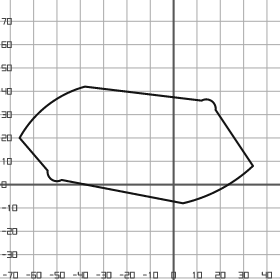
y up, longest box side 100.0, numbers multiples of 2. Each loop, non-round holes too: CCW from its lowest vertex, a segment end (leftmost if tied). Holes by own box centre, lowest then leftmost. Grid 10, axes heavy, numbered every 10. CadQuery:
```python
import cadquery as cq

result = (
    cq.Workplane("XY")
    .moveTo(4.0, -8.0)
    .threePointArc((20.0, -2.0), (34.0, 8.0))
    .lineTo(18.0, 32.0)
    .threePointArc((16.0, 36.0), (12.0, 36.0))
    .lineTo(-38.0, 42.0)
    .threePointArc((-54.0, 34.0), (-66.0, 20.0))
    .lineTo(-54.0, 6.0)
    .threePointArc((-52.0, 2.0), (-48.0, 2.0))
    .close()
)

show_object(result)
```